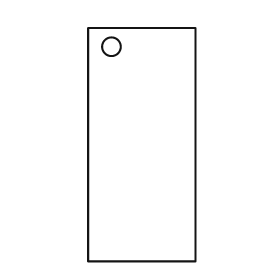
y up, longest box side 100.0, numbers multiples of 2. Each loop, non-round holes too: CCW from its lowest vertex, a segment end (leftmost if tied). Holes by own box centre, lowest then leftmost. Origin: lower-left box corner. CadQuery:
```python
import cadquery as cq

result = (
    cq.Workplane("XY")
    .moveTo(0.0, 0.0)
    .lineTo(46.0, 0.0)
    .lineTo(46.0, 100.0)
    .lineTo(0.0, 100.0)
    .close()
    .moveTo(10.0, 92.0)
    .circle(4.0)
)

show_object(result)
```